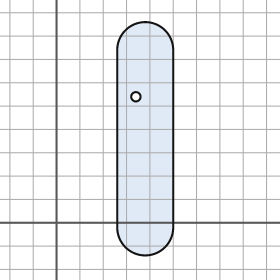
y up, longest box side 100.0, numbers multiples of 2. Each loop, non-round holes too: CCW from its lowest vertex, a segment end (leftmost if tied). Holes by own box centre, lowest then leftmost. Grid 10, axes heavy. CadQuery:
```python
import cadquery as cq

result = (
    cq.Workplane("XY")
    .moveTo(26.0, -2.0)
    .threePointArc((38.0, -14.0), (50.0, -2.0))
    .lineTo(50.0, 74.0)
    .threePointArc((38.0, 86.0), (26.0, 74.0))
    .close()
    .moveTo(34.0, 54.0)
    .circle(2.0)
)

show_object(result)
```